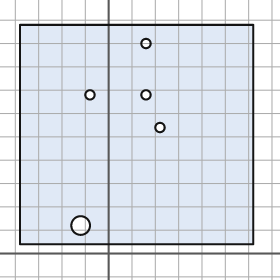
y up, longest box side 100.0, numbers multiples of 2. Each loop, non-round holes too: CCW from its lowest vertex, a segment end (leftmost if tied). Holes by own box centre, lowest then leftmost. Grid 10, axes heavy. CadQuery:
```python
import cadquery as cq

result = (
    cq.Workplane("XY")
    .moveTo(-38.0, 4.0)
    .lineTo(62.0, 4.0)
    .lineTo(62.0, 98.0)
    .lineTo(-38.0, 98.0)
    .close()
    .moveTo(-12.0, 12.0)
    .circle(4.0)
    .moveTo(22.0, 54.0)
    .circle(2.0)
    .moveTo(-8.0, 68.0)
    .circle(2.0)
    .moveTo(16.0, 68.0)
    .circle(2.0)
    .moveTo(16.0, 90.0)
    .circle(2.0)
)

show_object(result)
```